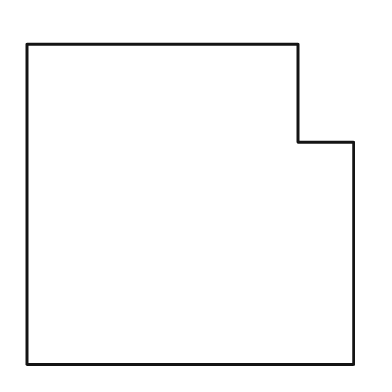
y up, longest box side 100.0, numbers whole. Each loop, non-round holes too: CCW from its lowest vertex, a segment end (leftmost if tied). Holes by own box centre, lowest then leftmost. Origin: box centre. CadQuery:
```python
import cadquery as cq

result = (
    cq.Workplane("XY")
    .moveTo(-50.0, -49.0)
    .lineTo(50.0, -49.0)
    .lineTo(50.0, 19.0)
    .lineTo(33.0, 19.0)
    .lineTo(33.0, 49.0)
    .lineTo(-50.0, 49.0)
    .close()
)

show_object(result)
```